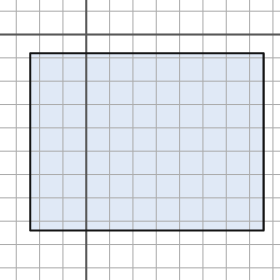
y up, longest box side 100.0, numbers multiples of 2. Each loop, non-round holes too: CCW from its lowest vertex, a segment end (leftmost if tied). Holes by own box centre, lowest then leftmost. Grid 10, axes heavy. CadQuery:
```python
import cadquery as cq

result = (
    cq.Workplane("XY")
    .moveTo(-24.0, -84.0)
    .lineTo(76.0, -84.0)
    .lineTo(76.0, -8.0)
    .lineTo(-24.0, -8.0)
    .close()
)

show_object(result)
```